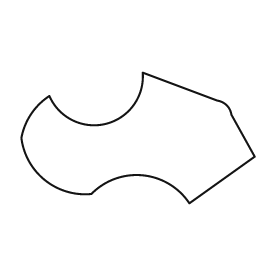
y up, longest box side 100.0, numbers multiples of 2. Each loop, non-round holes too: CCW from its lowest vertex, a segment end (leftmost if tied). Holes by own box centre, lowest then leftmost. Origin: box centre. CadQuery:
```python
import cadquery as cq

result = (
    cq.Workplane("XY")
    .moveTo(22.0, -28.0)
    .lineTo(50.0, -8.0)
    .lineTo(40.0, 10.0)
    .threePointArc((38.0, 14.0), (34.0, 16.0))
    .lineTo(2.0, 28.0)
    .threePointArc((-14.0, 6.0), (-38.0, 18.0))
    .threePointArc((-46.0, 10.0), (-50.0, 0.0))
    .threePointArc((-40.0, -18.0), (-20.0, -24.0))
    .threePointArc((2.0, -16.0), (22.0, -28.0))
    .close()
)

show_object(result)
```